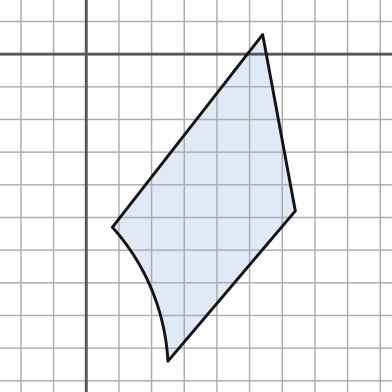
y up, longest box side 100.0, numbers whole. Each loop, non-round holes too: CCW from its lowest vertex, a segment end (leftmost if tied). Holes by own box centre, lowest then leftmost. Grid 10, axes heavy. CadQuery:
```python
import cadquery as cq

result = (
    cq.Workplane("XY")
    .moveTo(25.0, -94.0)
    .lineTo(64.0, -48.0)
    .lineTo(54.0, 6.0)
    .lineTo(8.0, -53.0)
    .threePointArc((20.0, -72.0), (25.0, -94.0))
    .close()
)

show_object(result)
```